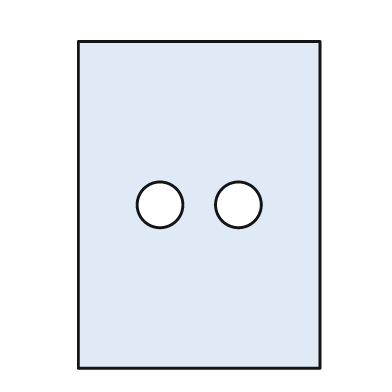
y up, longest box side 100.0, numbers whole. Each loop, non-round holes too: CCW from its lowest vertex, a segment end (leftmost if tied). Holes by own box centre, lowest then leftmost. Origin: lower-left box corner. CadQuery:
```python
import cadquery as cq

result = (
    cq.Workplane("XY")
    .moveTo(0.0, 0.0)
    .lineTo(74.0, 0.0)
    .lineTo(74.0, 100.0)
    .lineTo(0.0, 100.0)
    .close()
    .moveTo(25.0, 50.0)
    .circle(7.0)
    .moveTo(49.0, 50.0)
    .circle(7.0)
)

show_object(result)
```